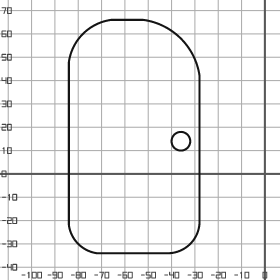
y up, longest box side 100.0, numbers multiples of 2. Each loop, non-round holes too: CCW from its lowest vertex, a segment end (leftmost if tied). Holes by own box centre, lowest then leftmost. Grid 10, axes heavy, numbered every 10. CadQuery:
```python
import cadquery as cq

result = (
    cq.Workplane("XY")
    .moveTo(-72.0, -34.0)
    .lineTo(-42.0, -34.0)
    .threePointArc((-32.0, -30.0), (-28.0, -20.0))
    .lineTo(-28.0, 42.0)
    .threePointArc((-36.0, 58.0), (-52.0, 66.0))
    .lineTo(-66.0, 66.0)
    .threePointArc((-78.0, 60.0), (-84.0, 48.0))
    .lineTo(-84.0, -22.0)
    .threePointArc((-80.0, -30.0), (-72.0, -34.0))
    .close()
    .moveTo(-36.0, 14.0)
    .circle(4.0)
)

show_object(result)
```